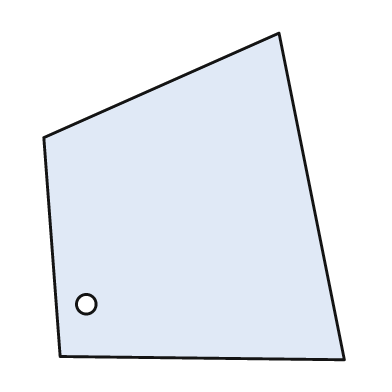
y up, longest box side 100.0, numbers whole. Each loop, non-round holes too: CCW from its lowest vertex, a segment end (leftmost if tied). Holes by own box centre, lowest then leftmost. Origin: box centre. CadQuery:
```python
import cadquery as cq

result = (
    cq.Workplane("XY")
    .moveTo(46.0, -50.0)
    .lineTo(26.0, 50.0)
    .lineTo(-46.0, 18.0)
    .lineTo(-41.0, -49.0)
    .close()
    .moveTo(-33.0, -33.0)
    .circle(3.0)
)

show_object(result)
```